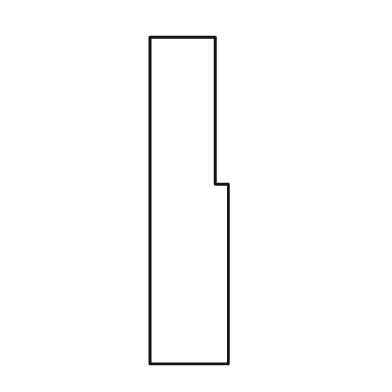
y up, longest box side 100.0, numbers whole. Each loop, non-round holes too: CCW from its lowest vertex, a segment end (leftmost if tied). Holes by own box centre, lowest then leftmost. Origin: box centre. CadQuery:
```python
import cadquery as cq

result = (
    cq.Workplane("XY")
    .moveTo(-12.0, -50.0)
    .lineTo(12.0, -50.0)
    .lineTo(12.0, 5.0)
    .lineTo(8.0, 5.0)
    .lineTo(8.0, 50.0)
    .lineTo(-12.0, 50.0)
    .close()
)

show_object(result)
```